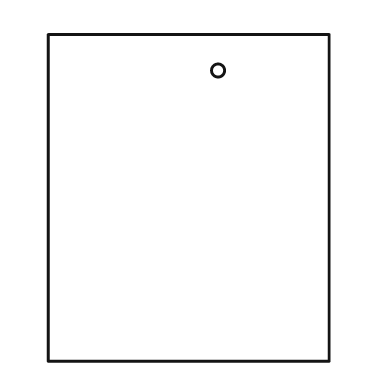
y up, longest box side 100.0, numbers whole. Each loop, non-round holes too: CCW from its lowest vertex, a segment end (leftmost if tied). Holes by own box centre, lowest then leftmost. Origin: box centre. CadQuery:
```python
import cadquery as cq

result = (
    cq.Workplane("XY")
    .moveTo(-43.0, -50.0)
    .lineTo(43.0, -50.0)
    .lineTo(43.0, 50.0)
    .lineTo(-43.0, 50.0)
    .close()
    .moveTo(9.0, 39.0)
    .circle(2.0)
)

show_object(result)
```